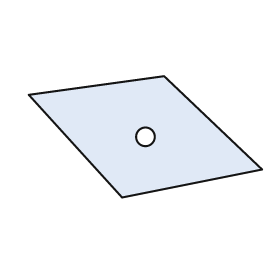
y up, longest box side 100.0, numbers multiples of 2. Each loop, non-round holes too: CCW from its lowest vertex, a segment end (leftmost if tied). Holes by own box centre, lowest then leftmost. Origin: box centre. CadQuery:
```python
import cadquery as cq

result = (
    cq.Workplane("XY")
    .moveTo(-10.0, -26.0)
    .lineTo(50.0, -14.0)
    .lineTo(8.0, 26.0)
    .lineTo(-50.0, 18.0)
    .close()
    .moveTo(0.0, 0.0)
    .circle(4.0)
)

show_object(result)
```